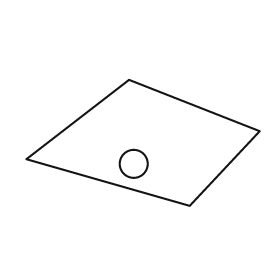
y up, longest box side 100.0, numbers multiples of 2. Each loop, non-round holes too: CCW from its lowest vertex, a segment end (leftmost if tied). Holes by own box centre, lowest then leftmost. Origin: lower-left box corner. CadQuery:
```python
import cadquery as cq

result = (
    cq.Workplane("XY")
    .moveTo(70.0, 0.0)
    .lineTo(100.0, 32.0)
    .lineTo(44.0, 54.0)
    .lineTo(0.0, 20.0)
    .close()
    .moveTo(46.0, 18.0)
    .circle(6.0)
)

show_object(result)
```